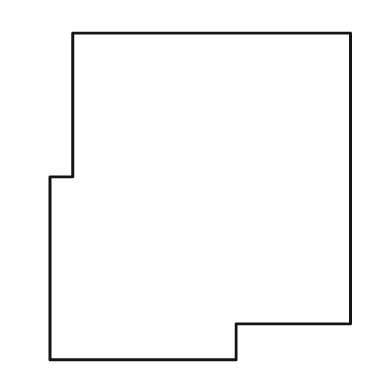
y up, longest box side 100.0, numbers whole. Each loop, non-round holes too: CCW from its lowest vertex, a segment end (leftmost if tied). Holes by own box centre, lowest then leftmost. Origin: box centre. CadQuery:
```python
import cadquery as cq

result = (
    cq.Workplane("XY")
    .moveTo(-46.0, -50.0)
    .lineTo(11.0, -50.0)
    .lineTo(11.0, -39.0)
    .lineTo(46.0, -39.0)
    .lineTo(46.0, 50.0)
    .lineTo(-39.0, 50.0)
    .lineTo(-39.0, 6.0)
    .lineTo(-46.0, 6.0)
    .close()
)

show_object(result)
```